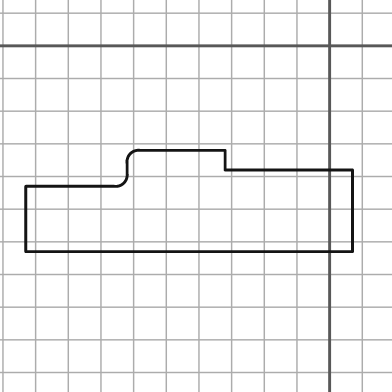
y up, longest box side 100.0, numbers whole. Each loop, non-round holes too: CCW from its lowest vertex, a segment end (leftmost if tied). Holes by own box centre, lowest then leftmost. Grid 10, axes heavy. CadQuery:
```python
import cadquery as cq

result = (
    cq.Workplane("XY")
    .moveTo(-93.0, -63.0)
    .lineTo(7.0, -63.0)
    .lineTo(7.0, -38.0)
    .lineTo(-32.0, -38.0)
    .lineTo(-32.0, -32.0)
    .lineTo(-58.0, -32.0)
    .threePointArc((-61.0, -33.0), (-62.0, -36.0))
    .lineTo(-62.0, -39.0)
    .threePointArc((-63.0, -42.0), (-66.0, -43.0))
    .lineTo(-93.0, -43.0)
    .close()
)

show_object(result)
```